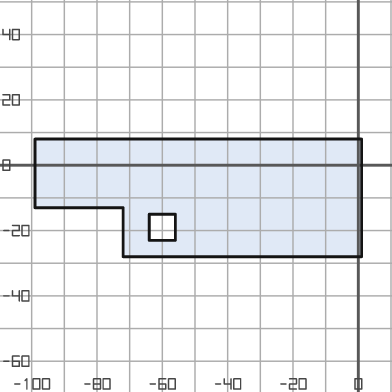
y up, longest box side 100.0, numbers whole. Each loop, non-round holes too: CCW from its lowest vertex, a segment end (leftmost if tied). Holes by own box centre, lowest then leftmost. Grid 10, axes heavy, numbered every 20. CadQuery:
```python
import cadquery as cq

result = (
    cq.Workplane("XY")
    .moveTo(-72.0, -28.0)
    .lineTo(1.0, -28.0)
    .lineTo(1.0, 8.0)
    .lineTo(-99.0, 8.0)
    .lineTo(-99.0, -13.0)
    .lineTo(-72.0, -13.0)
    .close()
    .moveTo(-64.0, -23.0)
    .lineTo(-56.0, -23.0)
    .lineTo(-56.0, -15.0)
    .lineTo(-64.0, -15.0)
    .close()
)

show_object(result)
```